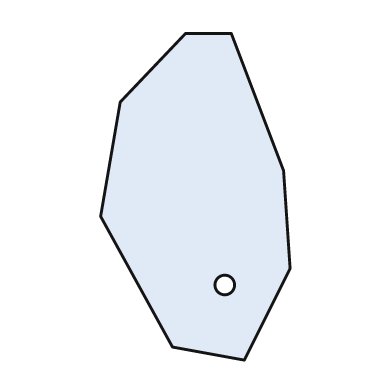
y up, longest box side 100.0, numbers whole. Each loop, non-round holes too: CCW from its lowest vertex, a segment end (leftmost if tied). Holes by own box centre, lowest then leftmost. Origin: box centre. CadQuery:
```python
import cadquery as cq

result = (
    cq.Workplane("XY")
    .moveTo(15.0, -50.0)
    .lineTo(29.0, -22.0)
    .lineTo(27.0, 8.0)
    .lineTo(11.0, 50.0)
    .lineTo(-3.0, 50.0)
    .lineTo(-23.0, 29.0)
    .lineTo(-29.0, -6.0)
    .lineTo(-7.0, -46.0)
    .close()
    .moveTo(9.0, -27.0)
    .circle(3.0)
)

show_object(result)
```